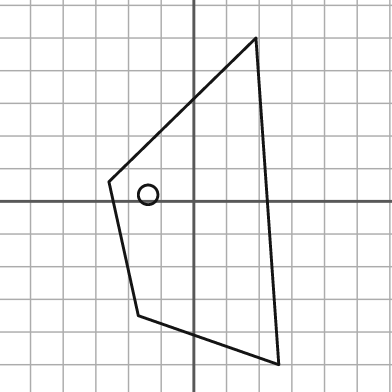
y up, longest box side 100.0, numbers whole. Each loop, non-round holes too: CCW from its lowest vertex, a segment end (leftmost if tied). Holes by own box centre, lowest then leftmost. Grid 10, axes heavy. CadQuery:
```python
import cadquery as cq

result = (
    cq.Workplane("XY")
    .moveTo(26.0, -50.0)
    .lineTo(19.0, 50.0)
    .lineTo(-26.0, 6.0)
    .lineTo(-17.0, -35.0)
    .close()
    .moveTo(-14.0, 2.0)
    .circle(3.0)
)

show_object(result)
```